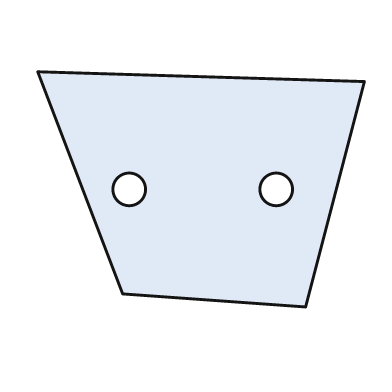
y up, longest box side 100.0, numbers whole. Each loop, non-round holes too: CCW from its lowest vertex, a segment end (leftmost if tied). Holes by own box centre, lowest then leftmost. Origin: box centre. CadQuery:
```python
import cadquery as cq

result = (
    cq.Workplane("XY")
    .moveTo(32.0, -36.0)
    .lineTo(50.0, 33.0)
    .lineTo(-50.0, 36.0)
    .lineTo(-24.0, -32.0)
    .close()
    .moveTo(-22.0, 0.0)
    .circle(5.0)
    .moveTo(23.0, 0.0)
    .circle(5.0)
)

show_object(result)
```